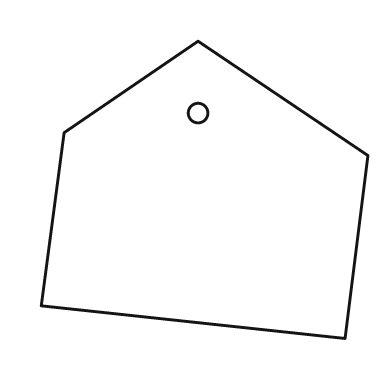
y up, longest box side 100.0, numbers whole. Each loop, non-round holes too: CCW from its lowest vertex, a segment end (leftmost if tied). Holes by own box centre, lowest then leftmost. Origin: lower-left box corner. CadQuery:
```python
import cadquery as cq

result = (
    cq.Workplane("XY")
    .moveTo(93.0, 0.0)
    .lineTo(100.0, 56.0)
    .lineTo(48.0, 91.0)
    .lineTo(7.0, 63.0)
    .lineTo(0.0, 10.0)
    .close()
    .moveTo(48.0, 69.0)
    .circle(3.0)
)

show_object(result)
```